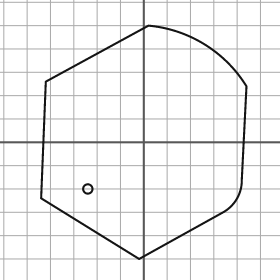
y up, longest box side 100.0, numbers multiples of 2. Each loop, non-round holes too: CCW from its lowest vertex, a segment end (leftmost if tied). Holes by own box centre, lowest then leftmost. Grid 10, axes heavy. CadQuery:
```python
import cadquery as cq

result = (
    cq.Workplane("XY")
    .moveTo(-2.0, -50.0)
    .lineTo(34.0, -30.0)
    .threePointArc((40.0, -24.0), (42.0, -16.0))
    .lineTo(44.0, 24.0)
    .threePointArc((26.0, 42.0), (2.0, 50.0))
    .lineTo(-42.0, 26.0)
    .lineTo(-44.0, -24.0)
    .close()
    .moveTo(-24.0, -20.0)
    .circle(2.0)
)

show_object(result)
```